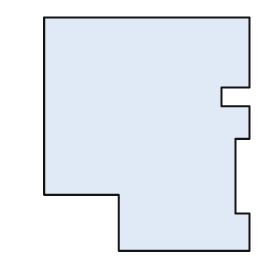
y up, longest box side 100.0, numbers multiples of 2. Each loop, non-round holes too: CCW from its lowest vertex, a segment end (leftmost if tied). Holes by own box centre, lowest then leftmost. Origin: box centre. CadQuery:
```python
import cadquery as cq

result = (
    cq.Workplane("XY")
    .moveTo(-12.0, -50.0)
    .lineTo(44.0, -50.0)
    .lineTo(44.0, -34.0)
    .lineTo(38.0, -34.0)
    .lineTo(38.0, -2.0)
    .lineTo(44.0, -2.0)
    .lineTo(44.0, 12.0)
    .lineTo(32.0, 12.0)
    .lineTo(32.0, 20.0)
    .lineTo(44.0, 20.0)
    .lineTo(44.0, 50.0)
    .lineTo(-44.0, 50.0)
    .lineTo(-44.0, -26.0)
    .lineTo(-12.0, -26.0)
    .close()
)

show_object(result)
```